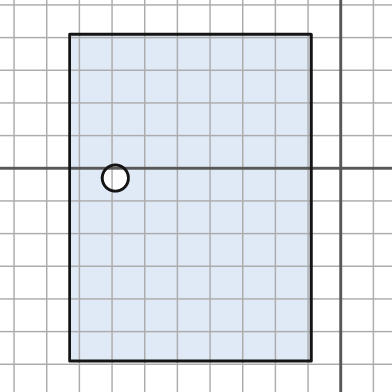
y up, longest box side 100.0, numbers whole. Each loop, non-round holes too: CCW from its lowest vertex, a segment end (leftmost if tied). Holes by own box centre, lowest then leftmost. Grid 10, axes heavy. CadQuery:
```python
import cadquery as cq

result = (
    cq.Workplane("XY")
    .moveTo(-83.0, -59.0)
    .lineTo(-9.0, -59.0)
    .lineTo(-9.0, 41.0)
    .lineTo(-83.0, 41.0)
    .close()
    .moveTo(-69.0, -3.0)
    .circle(4.0)
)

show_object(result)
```